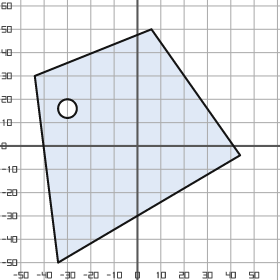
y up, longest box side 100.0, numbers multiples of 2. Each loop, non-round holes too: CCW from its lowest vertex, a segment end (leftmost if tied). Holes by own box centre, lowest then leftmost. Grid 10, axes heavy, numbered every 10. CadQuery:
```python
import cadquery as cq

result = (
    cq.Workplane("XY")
    .moveTo(-34.0, -50.0)
    .lineTo(44.0, -4.0)
    .lineTo(6.0, 50.0)
    .lineTo(-44.0, 30.0)
    .close()
    .moveTo(-30.0, 16.0)
    .circle(4.0)
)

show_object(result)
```